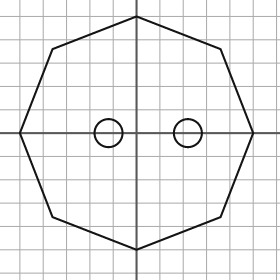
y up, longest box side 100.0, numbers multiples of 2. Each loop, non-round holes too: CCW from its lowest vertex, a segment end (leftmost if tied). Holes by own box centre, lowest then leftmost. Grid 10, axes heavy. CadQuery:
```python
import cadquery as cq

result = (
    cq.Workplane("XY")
    .moveTo(0.0, -50.0)
    .lineTo(36.0, -36.0)
    .lineTo(50.0, 0.0)
    .lineTo(36.0, 36.0)
    .lineTo(0.0, 50.0)
    .lineTo(-36.0, 36.0)
    .lineTo(-50.0, 0.0)
    .lineTo(-36.0, -36.0)
    .close()
    .moveTo(-12.0, 0.0)
    .circle(6.0)
    .moveTo(22.0, 0.0)
    .circle(6.0)
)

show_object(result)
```